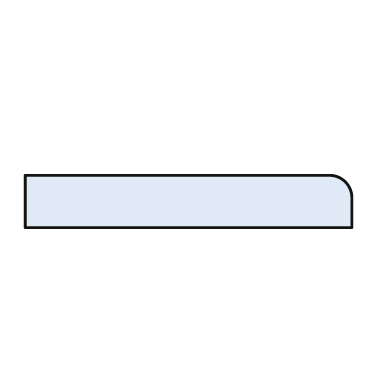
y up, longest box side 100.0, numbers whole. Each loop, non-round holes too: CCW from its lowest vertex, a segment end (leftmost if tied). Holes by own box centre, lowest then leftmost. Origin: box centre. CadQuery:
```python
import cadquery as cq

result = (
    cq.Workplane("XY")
    .moveTo(-50.0, -8.0)
    .lineTo(50.0, -8.0)
    .lineTo(50.0, 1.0)
    .threePointArc((48.0, 6.0), (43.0, 8.0))
    .lineTo(-50.0, 8.0)
    .close()
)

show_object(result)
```